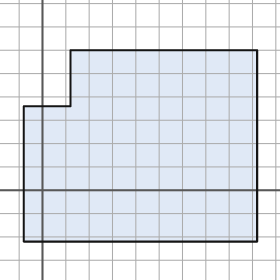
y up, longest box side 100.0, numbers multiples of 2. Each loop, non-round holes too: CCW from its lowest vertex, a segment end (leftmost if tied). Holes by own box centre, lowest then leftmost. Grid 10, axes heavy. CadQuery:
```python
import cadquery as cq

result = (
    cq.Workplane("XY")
    .moveTo(-8.0, -22.0)
    .lineTo(92.0, -22.0)
    .lineTo(92.0, 60.0)
    .lineTo(12.0, 60.0)
    .lineTo(12.0, 36.0)
    .lineTo(-8.0, 36.0)
    .close()
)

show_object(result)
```